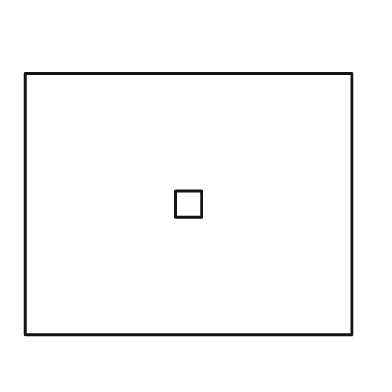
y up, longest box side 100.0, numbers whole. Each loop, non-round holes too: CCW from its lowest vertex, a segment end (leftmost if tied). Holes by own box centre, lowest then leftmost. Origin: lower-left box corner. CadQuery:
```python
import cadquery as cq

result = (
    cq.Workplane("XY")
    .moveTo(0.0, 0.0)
    .lineTo(100.0, 0.0)
    .lineTo(100.0, 80.0)
    .lineTo(0.0, 80.0)
    .close()
    .moveTo(46.0, 36.0)
    .lineTo(54.0, 36.0)
    .lineTo(54.0, 44.0)
    .lineTo(46.0, 44.0)
    .close()
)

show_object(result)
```